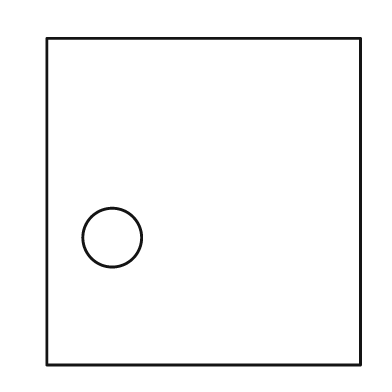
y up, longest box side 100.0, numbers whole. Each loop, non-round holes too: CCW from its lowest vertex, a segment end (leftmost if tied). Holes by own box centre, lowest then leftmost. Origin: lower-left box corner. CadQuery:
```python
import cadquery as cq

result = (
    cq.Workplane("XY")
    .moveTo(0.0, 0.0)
    .lineTo(96.0, 0.0)
    .lineTo(96.0, 100.0)
    .lineTo(0.0, 100.0)
    .close()
    .moveTo(20.0, 39.0)
    .circle(9.0)
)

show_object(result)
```